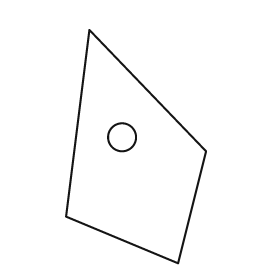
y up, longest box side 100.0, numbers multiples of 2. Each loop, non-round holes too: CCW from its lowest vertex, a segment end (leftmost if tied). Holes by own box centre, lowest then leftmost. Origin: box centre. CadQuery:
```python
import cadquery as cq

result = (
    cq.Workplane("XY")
    .moveTo(18.0, -50.0)
    .lineTo(30.0, -2.0)
    .lineTo(-20.0, 50.0)
    .lineTo(-30.0, -30.0)
    .close()
    .moveTo(-6.0, 4.0)
    .circle(6.0)
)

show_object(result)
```